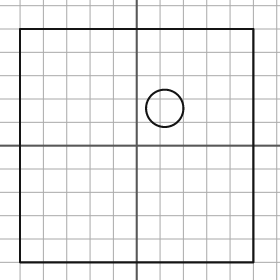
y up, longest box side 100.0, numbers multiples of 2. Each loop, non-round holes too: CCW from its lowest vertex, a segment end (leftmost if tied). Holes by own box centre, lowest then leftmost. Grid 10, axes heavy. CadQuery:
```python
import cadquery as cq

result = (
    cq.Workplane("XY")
    .moveTo(-50.0, -50.0)
    .lineTo(50.0, -50.0)
    .lineTo(50.0, 50.0)
    .lineTo(-50.0, 50.0)
    .close()
    .moveTo(12.0, 16.0)
    .circle(8.0)
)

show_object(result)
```